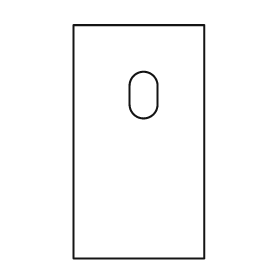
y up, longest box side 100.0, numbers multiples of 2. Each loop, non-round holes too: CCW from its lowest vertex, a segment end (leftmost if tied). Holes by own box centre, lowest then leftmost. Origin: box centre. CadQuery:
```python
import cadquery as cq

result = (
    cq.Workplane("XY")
    .moveTo(-28.0, -50.0)
    .lineTo(28.0, -50.0)
    .lineTo(28.0, 50.0)
    .lineTo(-28.0, 50.0)
    .close()
    .moveTo(-4.0, 16.0)
    .threePointArc((2.0, 10.0), (8.0, 16.0))
    .lineTo(8.0, 24.0)
    .threePointArc((2.0, 30.0), (-4.0, 24.0))
    .close()
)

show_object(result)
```